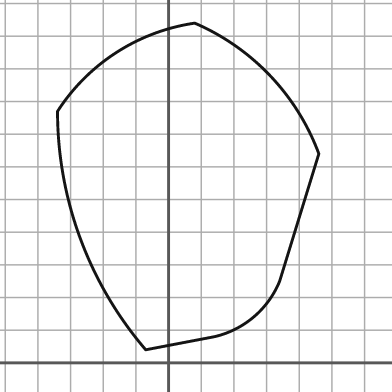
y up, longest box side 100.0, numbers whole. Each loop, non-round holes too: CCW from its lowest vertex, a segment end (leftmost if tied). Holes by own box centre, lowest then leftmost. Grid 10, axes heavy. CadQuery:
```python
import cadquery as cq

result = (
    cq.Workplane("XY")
    .moveTo(-7.0, 4.0)
    .lineTo(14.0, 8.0)
    .threePointArc((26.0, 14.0), (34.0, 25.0))
    .lineTo(46.0, 64.0)
    .threePointArc((31.0, 88.0), (8.0, 104.0))
    .threePointArc((-16.0, 95.0), (-34.0, 77.0))
    .threePointArc((-27.0, 38.0), (-7.0, 4.0))
    .close()
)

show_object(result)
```